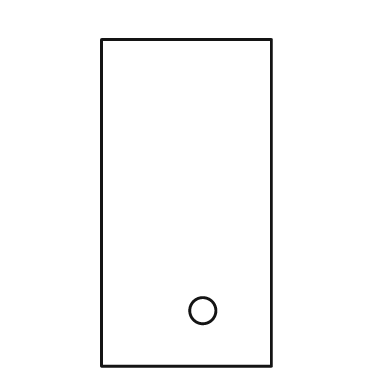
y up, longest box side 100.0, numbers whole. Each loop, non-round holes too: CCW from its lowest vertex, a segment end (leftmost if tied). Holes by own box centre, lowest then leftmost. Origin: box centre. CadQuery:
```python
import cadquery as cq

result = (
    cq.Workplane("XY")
    .moveTo(-26.0, -50.0)
    .lineTo(26.0, -50.0)
    .lineTo(26.0, 50.0)
    .lineTo(-26.0, 50.0)
    .close()
    .moveTo(5.0, -33.0)
    .circle(4.0)
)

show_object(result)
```